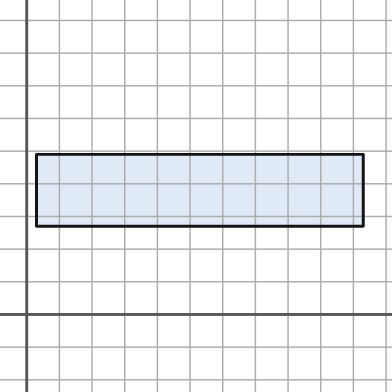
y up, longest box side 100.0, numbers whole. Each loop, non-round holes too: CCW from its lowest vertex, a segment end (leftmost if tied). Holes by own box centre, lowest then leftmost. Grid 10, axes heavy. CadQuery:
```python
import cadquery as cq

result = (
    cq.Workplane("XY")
    .moveTo(3.0, 27.0)
    .lineTo(103.0, 27.0)
    .lineTo(103.0, 49.0)
    .lineTo(3.0, 49.0)
    .close()
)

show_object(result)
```